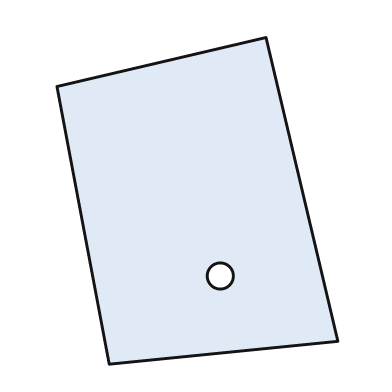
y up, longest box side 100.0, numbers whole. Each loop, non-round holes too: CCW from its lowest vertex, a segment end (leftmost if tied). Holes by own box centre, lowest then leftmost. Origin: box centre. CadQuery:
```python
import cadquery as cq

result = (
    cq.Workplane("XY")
    .moveTo(-27.0, -50.0)
    .lineTo(43.0, -43.0)
    .lineTo(21.0, 50.0)
    .lineTo(-43.0, 35.0)
    .close()
    .moveTo(7.0, -23.0)
    .circle(4.0)
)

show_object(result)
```